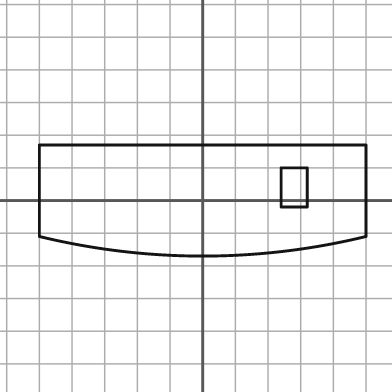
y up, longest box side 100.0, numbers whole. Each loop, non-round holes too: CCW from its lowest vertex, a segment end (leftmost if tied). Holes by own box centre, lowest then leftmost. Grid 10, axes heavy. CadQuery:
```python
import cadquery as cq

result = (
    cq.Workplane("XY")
    .moveTo(-50.0, -11.0)
    .threePointArc((0.0, -17.0), (50.0, -11.0))
    .lineTo(50.0, 17.0)
    .lineTo(-50.0, 17.0)
    .close()
    .moveTo(24.0, -2.0)
    .lineTo(32.0, -2.0)
    .lineTo(32.0, 10.0)
    .lineTo(24.0, 10.0)
    .close()
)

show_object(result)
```